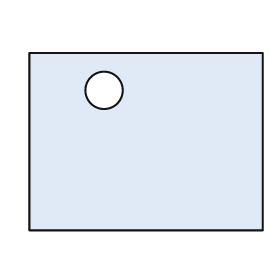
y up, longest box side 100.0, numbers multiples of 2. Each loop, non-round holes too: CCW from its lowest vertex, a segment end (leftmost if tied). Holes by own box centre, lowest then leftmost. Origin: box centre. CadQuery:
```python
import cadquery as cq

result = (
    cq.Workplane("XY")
    .moveTo(-50.0, -38.0)
    .lineTo(50.0, -38.0)
    .lineTo(50.0, 38.0)
    .lineTo(-50.0, 38.0)
    .close()
    .moveTo(-18.0, 22.0)
    .circle(8.0)
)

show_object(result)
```